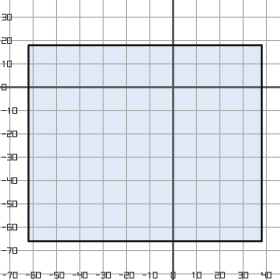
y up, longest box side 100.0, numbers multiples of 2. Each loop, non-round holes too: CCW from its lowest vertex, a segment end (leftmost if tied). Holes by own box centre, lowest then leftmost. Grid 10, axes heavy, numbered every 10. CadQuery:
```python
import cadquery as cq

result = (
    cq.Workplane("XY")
    .moveTo(-62.0, -66.0)
    .lineTo(38.0, -66.0)
    .lineTo(38.0, 18.0)
    .lineTo(-62.0, 18.0)
    .close()
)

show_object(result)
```